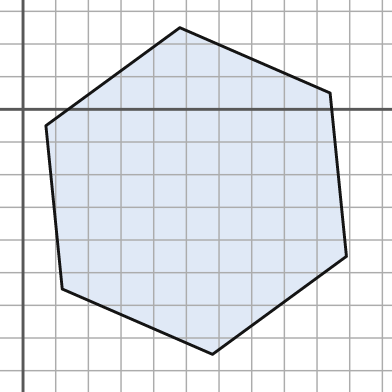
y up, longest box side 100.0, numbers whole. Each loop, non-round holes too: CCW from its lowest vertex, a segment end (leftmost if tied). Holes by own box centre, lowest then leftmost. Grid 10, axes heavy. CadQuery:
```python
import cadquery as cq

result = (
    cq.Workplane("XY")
    .moveTo(58.0, -75.0)
    .lineTo(99.0, -45.0)
    .lineTo(94.0, 5.0)
    .lineTo(48.0, 25.0)
    .lineTo(7.0, -5.0)
    .lineTo(12.0, -55.0)
    .close()
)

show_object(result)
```